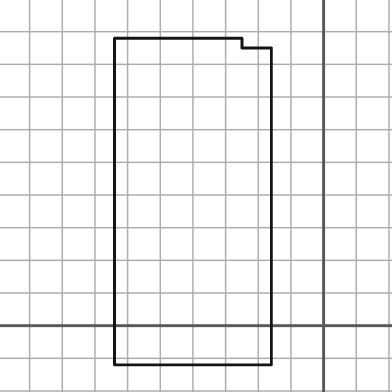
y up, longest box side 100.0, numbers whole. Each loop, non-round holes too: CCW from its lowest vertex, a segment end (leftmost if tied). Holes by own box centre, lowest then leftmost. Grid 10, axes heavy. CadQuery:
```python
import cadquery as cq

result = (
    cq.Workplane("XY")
    .moveTo(-64.0, -12.0)
    .lineTo(-16.0, -12.0)
    .lineTo(-16.0, 85.0)
    .lineTo(-25.0, 85.0)
    .lineTo(-25.0, 88.0)
    .lineTo(-64.0, 88.0)
    .close()
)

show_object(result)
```